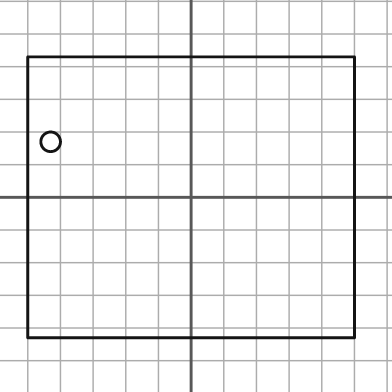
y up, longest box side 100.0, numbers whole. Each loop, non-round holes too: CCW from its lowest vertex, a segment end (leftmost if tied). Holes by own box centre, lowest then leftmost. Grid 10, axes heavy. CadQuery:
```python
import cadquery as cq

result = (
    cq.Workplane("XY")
    .moveTo(-50.0, -43.0)
    .lineTo(50.0, -43.0)
    .lineTo(50.0, 43.0)
    .lineTo(-50.0, 43.0)
    .close()
    .moveTo(-43.0, 17.0)
    .circle(3.0)
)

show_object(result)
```